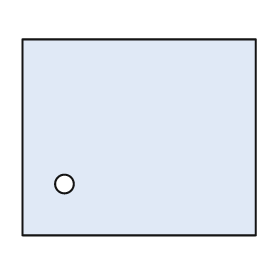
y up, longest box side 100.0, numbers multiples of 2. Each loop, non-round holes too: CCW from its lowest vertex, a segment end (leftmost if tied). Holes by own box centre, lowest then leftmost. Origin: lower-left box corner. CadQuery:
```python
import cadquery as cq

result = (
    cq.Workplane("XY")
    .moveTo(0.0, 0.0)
    .lineTo(100.0, 0.0)
    .lineTo(100.0, 84.0)
    .lineTo(0.0, 84.0)
    .close()
    .moveTo(18.0, 22.0)
    .circle(4.0)
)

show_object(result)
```